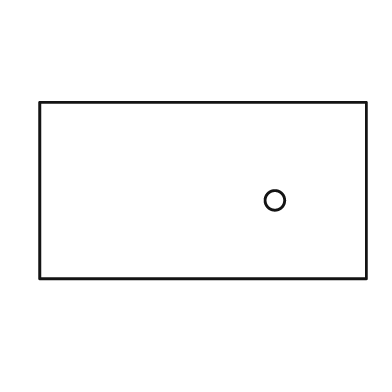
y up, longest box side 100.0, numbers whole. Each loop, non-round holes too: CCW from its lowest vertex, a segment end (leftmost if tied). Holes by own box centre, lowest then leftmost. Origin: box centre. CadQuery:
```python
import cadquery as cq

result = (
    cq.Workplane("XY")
    .moveTo(-50.0, -27.0)
    .lineTo(50.0, -27.0)
    .lineTo(50.0, 27.0)
    .lineTo(-50.0, 27.0)
    .close()
    .moveTo(22.0, -3.0)
    .circle(3.0)
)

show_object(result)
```